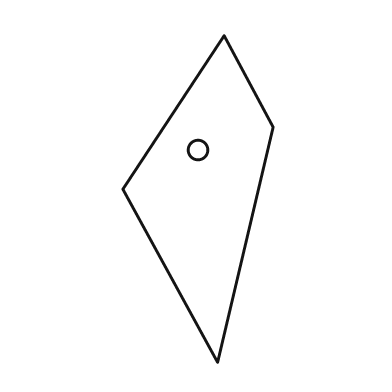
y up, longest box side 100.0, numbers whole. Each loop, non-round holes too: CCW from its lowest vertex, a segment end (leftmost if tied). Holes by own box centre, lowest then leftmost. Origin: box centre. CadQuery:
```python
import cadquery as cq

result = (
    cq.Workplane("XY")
    .moveTo(6.0, -50.0)
    .lineTo(23.0, 22.0)
    .lineTo(8.0, 50.0)
    .lineTo(-23.0, 3.0)
    .close()
    .moveTo(0.0, 15.0)
    .circle(3.0)
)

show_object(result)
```